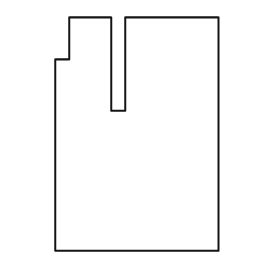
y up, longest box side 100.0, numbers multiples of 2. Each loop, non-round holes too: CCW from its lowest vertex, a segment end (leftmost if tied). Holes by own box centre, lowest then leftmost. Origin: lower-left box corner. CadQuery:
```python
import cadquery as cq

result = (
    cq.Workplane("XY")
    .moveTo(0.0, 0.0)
    .lineTo(70.0, 0.0)
    .lineTo(70.0, 100.0)
    .lineTo(30.0, 100.0)
    .lineTo(30.0, 60.0)
    .lineTo(24.0, 60.0)
    .lineTo(24.0, 100.0)
    .lineTo(6.0, 100.0)
    .lineTo(6.0, 82.0)
    .lineTo(0.0, 82.0)
    .close()
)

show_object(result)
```